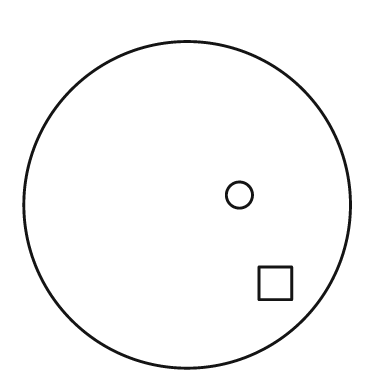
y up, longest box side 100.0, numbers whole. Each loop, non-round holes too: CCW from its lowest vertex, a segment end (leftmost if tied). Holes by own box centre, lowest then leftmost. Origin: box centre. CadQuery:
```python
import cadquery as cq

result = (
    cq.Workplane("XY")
    .moveTo(0.0, 0.0)
    .circle(50.0)
    .moveTo(22.0, -29.0)
    .lineTo(32.0, -29.0)
    .lineTo(32.0, -19.0)
    .lineTo(22.0, -19.0)
    .close()
    .moveTo(16.0, 3.0)
    .circle(4.0)
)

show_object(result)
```